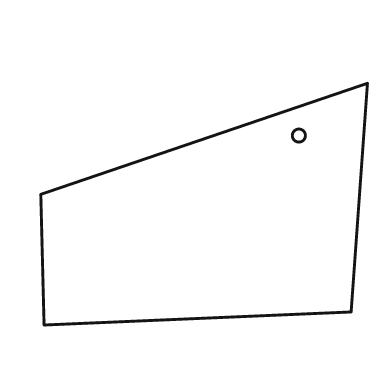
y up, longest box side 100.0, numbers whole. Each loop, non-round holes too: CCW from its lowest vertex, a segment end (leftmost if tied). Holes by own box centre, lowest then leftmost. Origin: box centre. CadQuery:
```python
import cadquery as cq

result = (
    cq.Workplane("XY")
    .moveTo(-49.0, -37.0)
    .lineTo(45.0, -33.0)
    .lineTo(50.0, 37.0)
    .lineTo(-50.0, 3.0)
    .close()
    .moveTo(29.0, 21.0)
    .circle(2.0)
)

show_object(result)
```